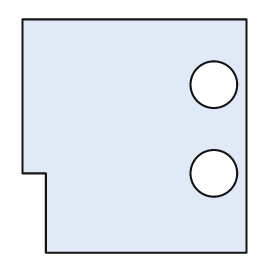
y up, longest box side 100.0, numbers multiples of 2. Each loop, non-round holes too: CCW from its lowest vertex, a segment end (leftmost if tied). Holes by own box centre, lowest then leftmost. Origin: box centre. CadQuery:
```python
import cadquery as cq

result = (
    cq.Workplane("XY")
    .moveTo(-38.0, -50.0)
    .lineTo(48.0, -50.0)
    .lineTo(48.0, 50.0)
    .lineTo(-48.0, 50.0)
    .lineTo(-48.0, -16.0)
    .lineTo(-38.0, -16.0)
    .close()
    .moveTo(34.0, -16.0)
    .circle(10.0)
    .moveTo(34.0, 22.0)
    .circle(10.0)
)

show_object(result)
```